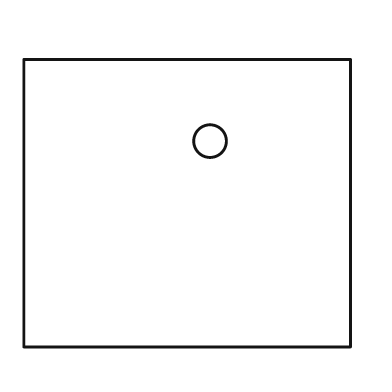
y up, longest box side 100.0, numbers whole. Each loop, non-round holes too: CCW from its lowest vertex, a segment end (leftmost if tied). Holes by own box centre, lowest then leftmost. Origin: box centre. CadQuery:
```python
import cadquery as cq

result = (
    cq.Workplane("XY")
    .moveTo(-50.0, -44.0)
    .lineTo(50.0, -44.0)
    .lineTo(50.0, 44.0)
    .lineTo(-50.0, 44.0)
    .close()
    .moveTo(7.0, 19.0)
    .circle(5.0)
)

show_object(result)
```